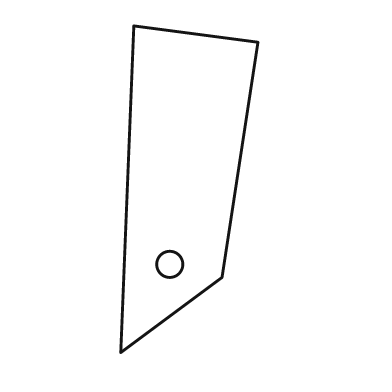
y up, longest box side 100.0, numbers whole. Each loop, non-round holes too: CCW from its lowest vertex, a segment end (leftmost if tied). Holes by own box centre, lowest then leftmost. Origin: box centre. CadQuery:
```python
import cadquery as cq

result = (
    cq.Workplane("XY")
    .moveTo(-21.0, -50.0)
    .lineTo(10.0, -27.0)
    .lineTo(21.0, 45.0)
    .lineTo(-17.0, 50.0)
    .close()
    .moveTo(-6.0, -23.0)
    .circle(4.0)
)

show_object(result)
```